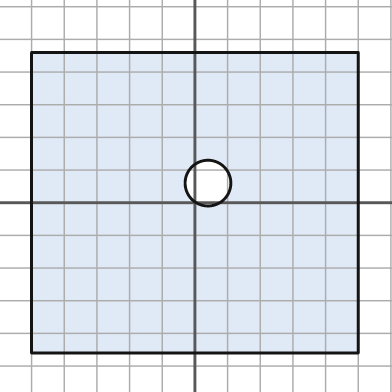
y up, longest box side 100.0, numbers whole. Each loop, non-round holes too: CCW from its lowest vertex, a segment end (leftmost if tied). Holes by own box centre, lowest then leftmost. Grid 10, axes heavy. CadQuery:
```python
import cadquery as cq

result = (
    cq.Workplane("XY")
    .moveTo(-50.0, -46.0)
    .lineTo(50.0, -46.0)
    .lineTo(50.0, 46.0)
    .lineTo(-50.0, 46.0)
    .close()
    .moveTo(4.0, 6.0)
    .circle(7.0)
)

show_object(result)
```